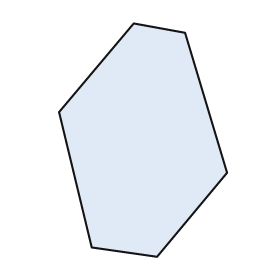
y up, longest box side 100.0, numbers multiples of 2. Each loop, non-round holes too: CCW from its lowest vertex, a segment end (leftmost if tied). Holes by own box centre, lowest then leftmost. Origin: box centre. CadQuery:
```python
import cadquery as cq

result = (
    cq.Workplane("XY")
    .moveTo(6.0, -50.0)
    .lineTo(36.0, -14.0)
    .lineTo(18.0, 46.0)
    .lineTo(-4.0, 50.0)
    .lineTo(-36.0, 12.0)
    .lineTo(-22.0, -46.0)
    .close()
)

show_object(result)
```